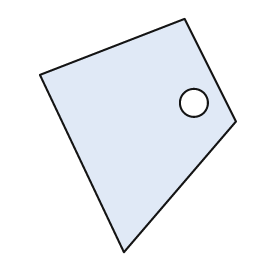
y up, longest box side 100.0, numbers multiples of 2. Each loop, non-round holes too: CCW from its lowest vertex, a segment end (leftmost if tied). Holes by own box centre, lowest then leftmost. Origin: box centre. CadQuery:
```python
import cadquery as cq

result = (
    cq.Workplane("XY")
    .moveTo(-6.0, -50.0)
    .lineTo(42.0, 6.0)
    .lineTo(20.0, 50.0)
    .lineTo(-42.0, 26.0)
    .close()
    .moveTo(24.0, 14.0)
    .circle(6.0)
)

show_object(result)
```